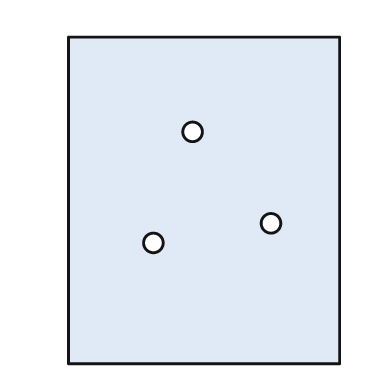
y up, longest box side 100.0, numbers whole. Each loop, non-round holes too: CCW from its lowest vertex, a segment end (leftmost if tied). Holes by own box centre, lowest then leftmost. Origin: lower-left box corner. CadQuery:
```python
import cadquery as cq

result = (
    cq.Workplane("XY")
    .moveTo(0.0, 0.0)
    .lineTo(83.0, 0.0)
    .lineTo(83.0, 100.0)
    .lineTo(0.0, 100.0)
    .close()
    .moveTo(26.0, 37.0)
    .circle(3.0)
    .moveTo(62.0, 43.0)
    .circle(3.0)
    .moveTo(38.0, 71.0)
    .circle(3.0)
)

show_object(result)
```